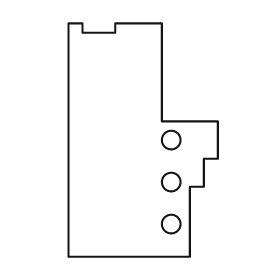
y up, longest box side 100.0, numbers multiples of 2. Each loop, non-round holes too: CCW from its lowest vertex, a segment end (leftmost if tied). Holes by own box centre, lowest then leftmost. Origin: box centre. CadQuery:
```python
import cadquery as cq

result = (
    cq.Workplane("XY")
    .moveTo(-32.0, -50.0)
    .lineTo(20.0, -50.0)
    .lineTo(20.0, -20.0)
    .lineTo(26.0, -20.0)
    .lineTo(26.0, -8.0)
    .lineTo(32.0, -8.0)
    .lineTo(32.0, 8.0)
    .lineTo(8.0, 8.0)
    .lineTo(8.0, 50.0)
    .lineTo(-12.0, 50.0)
    .lineTo(-12.0, 46.0)
    .lineTo(-26.0, 46.0)
    .lineTo(-26.0, 50.0)
    .lineTo(-32.0, 50.0)
    .close()
    .moveTo(12.0, -36.0)
    .circle(4.0)
    .moveTo(12.0, -18.0)
    .circle(4.0)
    .moveTo(12.0, 0.0)
    .circle(4.0)
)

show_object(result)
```